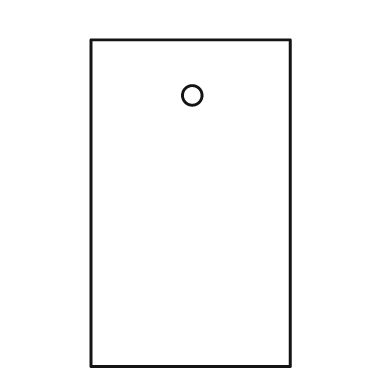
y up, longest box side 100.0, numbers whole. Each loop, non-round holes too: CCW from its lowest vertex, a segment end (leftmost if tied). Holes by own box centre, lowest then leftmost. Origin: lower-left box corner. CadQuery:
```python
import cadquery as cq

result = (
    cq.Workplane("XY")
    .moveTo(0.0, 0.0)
    .lineTo(61.0, 0.0)
    .lineTo(61.0, 100.0)
    .lineTo(0.0, 100.0)
    .close()
    .moveTo(31.0, 83.0)
    .circle(3.0)
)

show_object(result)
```